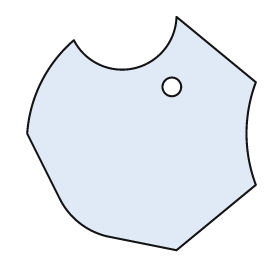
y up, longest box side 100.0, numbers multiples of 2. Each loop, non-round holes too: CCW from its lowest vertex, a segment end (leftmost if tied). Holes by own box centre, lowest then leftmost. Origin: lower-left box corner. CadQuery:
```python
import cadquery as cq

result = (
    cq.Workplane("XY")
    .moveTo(64.0, 0.0)
    .lineTo(98.0, 28.0)
    .threePointArc((94.0, 50.0), (98.0, 72.0))
    .lineTo(64.0, 100.0)
    .threePointArc((46.0, 78.0), (20.0, 90.0))
    .threePointArc((6.0, 72.0), (0.0, 50.0))
    .lineTo(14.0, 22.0)
    .threePointArc((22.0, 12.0), (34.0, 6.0))
    .close()
    .moveTo(62.0, 70.0)
    .circle(4.0)
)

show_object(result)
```